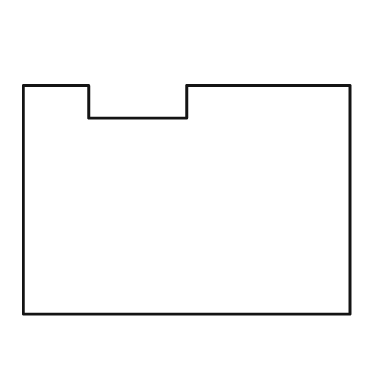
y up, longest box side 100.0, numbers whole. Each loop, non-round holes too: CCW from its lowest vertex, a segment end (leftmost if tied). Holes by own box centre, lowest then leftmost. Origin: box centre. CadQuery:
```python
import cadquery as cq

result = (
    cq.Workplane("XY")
    .moveTo(-50.0, -35.0)
    .lineTo(50.0, -35.0)
    .lineTo(50.0, 35.0)
    .lineTo(0.0, 35.0)
    .lineTo(0.0, 25.0)
    .lineTo(-30.0, 25.0)
    .lineTo(-30.0, 35.0)
    .lineTo(-50.0, 35.0)
    .close()
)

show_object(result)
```